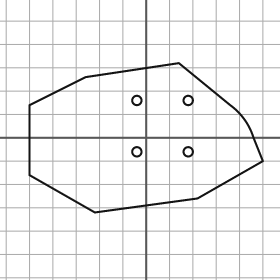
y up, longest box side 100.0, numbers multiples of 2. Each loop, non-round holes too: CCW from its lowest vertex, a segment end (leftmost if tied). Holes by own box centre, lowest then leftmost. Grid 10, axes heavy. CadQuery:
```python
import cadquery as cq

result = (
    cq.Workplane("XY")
    .moveTo(-22.0, -32.0)
    .lineTo(22.0, -26.0)
    .lineTo(50.0, -10.0)
    .lineTo(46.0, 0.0)
    .threePointArc((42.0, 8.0), (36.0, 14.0))
    .lineTo(14.0, 32.0)
    .lineTo(-26.0, 26.0)
    .lineTo(-50.0, 14.0)
    .lineTo(-50.0, -16.0)
    .close()
    .moveTo(-4.0, -6.0)
    .circle(2.0)
    .moveTo(18.0, -6.0)
    .circle(2.0)
    .moveTo(-4.0, 16.0)
    .circle(2.0)
    .moveTo(18.0, 16.0)
    .circle(2.0)
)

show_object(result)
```